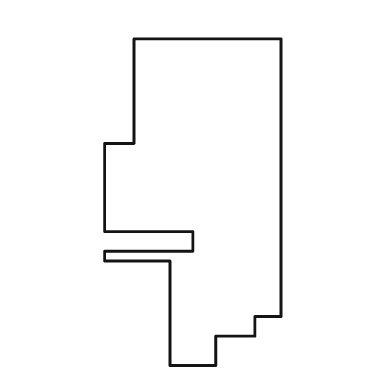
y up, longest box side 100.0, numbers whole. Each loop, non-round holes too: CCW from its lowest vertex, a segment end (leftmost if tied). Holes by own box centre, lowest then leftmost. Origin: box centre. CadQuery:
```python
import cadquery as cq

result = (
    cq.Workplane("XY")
    .moveTo(-7.0, -50.0)
    .lineTo(7.0, -50.0)
    .lineTo(7.0, -41.0)
    .lineTo(19.0, -41.0)
    .lineTo(19.0, -35.0)
    .lineTo(27.0, -35.0)
    .lineTo(27.0, 50.0)
    .lineTo(-18.0, 50.0)
    .lineTo(-18.0, 18.0)
    .lineTo(-27.0, 18.0)
    .lineTo(-27.0, -9.0)
    .lineTo(0.0, -9.0)
    .lineTo(0.0, -15.0)
    .lineTo(-27.0, -15.0)
    .lineTo(-27.0, -18.0)
    .lineTo(-7.0, -18.0)
    .close()
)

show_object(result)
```